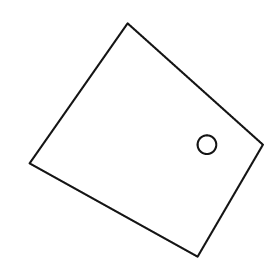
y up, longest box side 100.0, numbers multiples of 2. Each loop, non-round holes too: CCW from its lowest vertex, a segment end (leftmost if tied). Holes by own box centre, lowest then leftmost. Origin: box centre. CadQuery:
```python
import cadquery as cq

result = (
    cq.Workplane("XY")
    .moveTo(22.0, -50.0)
    .lineTo(50.0, -2.0)
    .lineTo(-8.0, 50.0)
    .lineTo(-50.0, -10.0)
    .close()
    .moveTo(26.0, -2.0)
    .circle(4.0)
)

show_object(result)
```